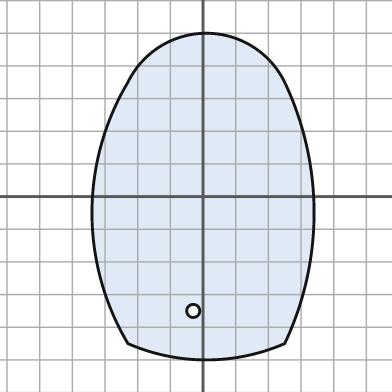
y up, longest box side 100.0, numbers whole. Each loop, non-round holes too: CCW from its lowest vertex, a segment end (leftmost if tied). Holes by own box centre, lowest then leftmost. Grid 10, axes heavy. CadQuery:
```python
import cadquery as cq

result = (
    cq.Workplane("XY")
    .moveTo(-23.0, -45.0)
    .threePointArc((1.0, -50.0), (25.0, -45.0))
    .threePointArc((34.0, -5.0), (25.0, 35.0))
    .threePointArc((1.0, 50.0), (-23.0, 35.0))
    .threePointArc((-34.0, -5.0), (-23.0, -45.0))
    .close()
    .moveTo(-3.0, -35.0)
    .circle(2.0)
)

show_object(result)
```